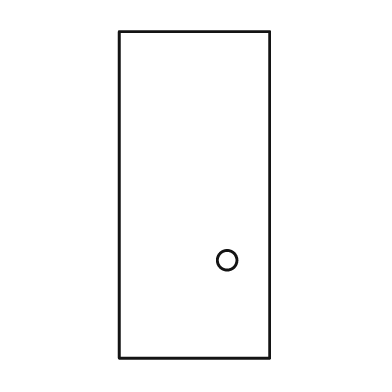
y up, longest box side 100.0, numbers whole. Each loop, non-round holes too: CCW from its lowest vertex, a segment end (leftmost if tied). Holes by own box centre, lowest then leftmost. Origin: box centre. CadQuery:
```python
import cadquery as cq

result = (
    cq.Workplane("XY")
    .moveTo(-23.0, -50.0)
    .lineTo(23.0, -50.0)
    .lineTo(23.0, 50.0)
    .lineTo(-23.0, 50.0)
    .close()
    .moveTo(10.0, -20.0)
    .circle(3.0)
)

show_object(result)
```